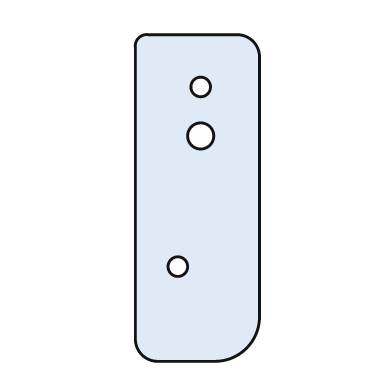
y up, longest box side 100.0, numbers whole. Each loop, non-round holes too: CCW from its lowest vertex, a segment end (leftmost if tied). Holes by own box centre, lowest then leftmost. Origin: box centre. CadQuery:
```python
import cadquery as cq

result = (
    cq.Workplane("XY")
    .moveTo(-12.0, -50.0)
    .lineTo(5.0, -50.0)
    .threePointArc((15.0, -46.0), (19.0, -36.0))
    .lineTo(19.0, 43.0)
    .threePointArc((17.0, 48.0), (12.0, 50.0))
    .lineTo(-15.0, 50.0)
    .threePointArc((-18.0, 49.0), (-19.0, 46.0))
    .lineTo(-19.0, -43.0)
    .threePointArc((-17.0, -48.0), (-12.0, -50.0))
    .close()
    .moveTo(-6.0, -21.0)
    .circle(3.0)
    .moveTo(1.0, 19.0)
    .circle(4.0)
    .moveTo(1.0, 34.0)
    .circle(3.0)
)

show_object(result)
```